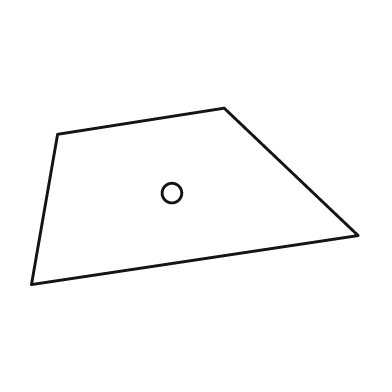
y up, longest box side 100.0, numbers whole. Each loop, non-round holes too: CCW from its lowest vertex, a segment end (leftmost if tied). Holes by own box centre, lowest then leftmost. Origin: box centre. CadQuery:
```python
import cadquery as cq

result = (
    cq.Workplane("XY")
    .moveTo(-50.0, -27.0)
    .lineTo(50.0, -12.0)
    .lineTo(9.0, 27.0)
    .lineTo(-42.0, 19.0)
    .close()
    .moveTo(-7.0, 1.0)
    .circle(3.0)
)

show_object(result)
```